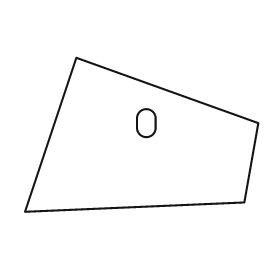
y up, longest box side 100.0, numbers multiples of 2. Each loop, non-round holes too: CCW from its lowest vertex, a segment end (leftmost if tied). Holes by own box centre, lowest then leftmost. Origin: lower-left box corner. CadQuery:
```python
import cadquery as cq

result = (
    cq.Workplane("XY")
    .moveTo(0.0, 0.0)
    .lineTo(94.0, 4.0)
    .lineTo(100.0, 38.0)
    .lineTo(22.0, 66.0)
    .close()
    .moveTo(48.0, 36.0)
    .threePointArc((52.0, 32.0), (56.0, 36.0))
    .lineTo(56.0, 40.0)
    .threePointArc((52.0, 44.0), (48.0, 40.0))
    .close()
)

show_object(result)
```